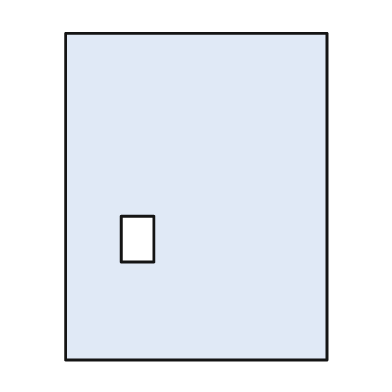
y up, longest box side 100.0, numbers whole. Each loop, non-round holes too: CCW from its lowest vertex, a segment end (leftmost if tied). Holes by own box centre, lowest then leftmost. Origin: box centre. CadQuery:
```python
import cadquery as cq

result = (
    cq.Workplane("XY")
    .moveTo(-40.0, -50.0)
    .lineTo(40.0, -50.0)
    .lineTo(40.0, 50.0)
    .lineTo(-40.0, 50.0)
    .close()
    .moveTo(-23.0, -20.0)
    .lineTo(-13.0, -20.0)
    .lineTo(-13.0, -6.0)
    .lineTo(-23.0, -6.0)
    .close()
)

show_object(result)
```